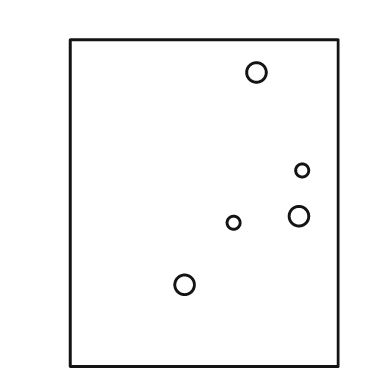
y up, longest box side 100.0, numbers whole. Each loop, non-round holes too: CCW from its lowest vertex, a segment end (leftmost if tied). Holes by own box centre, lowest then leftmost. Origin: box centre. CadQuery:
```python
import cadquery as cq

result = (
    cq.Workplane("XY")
    .moveTo(-41.0, -50.0)
    .lineTo(41.0, -50.0)
    .lineTo(41.0, 50.0)
    .lineTo(-41.0, 50.0)
    .close()
    .moveTo(-6.0, -25.0)
    .circle(3.0)
    .moveTo(9.0, -6.0)
    .circle(2.0)
    .moveTo(29.0, -4.0)
    .circle(3.0)
    .moveTo(30.0, 10.0)
    .circle(2.0)
    .moveTo(16.0, 40.0)
    .circle(3.0)
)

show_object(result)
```